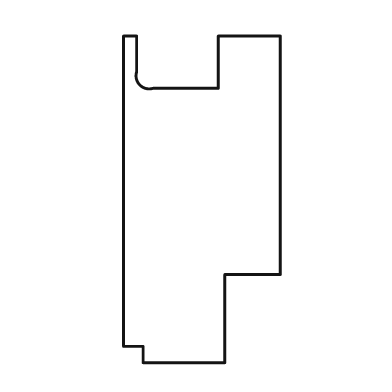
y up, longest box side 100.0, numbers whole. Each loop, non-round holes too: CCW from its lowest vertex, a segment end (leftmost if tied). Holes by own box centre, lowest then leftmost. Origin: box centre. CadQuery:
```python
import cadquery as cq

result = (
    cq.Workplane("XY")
    .moveTo(-18.0, -50.0)
    .lineTo(7.0, -50.0)
    .lineTo(7.0, -23.0)
    .lineTo(24.0, -23.0)
    .lineTo(24.0, 50.0)
    .lineTo(5.0, 50.0)
    .lineTo(5.0, 34.0)
    .lineTo(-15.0, 34.0)
    .threePointArc((-19.0, 35.0), (-20.0, 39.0))
    .lineTo(-20.0, 50.0)
    .lineTo(-24.0, 50.0)
    .lineTo(-24.0, -45.0)
    .lineTo(-18.0, -45.0)
    .close()
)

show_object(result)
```